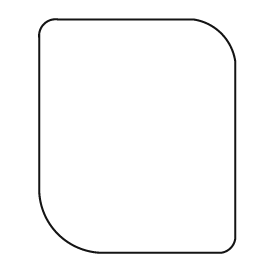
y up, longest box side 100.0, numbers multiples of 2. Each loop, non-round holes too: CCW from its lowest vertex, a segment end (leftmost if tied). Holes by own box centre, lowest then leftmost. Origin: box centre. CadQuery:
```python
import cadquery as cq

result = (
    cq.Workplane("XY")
    .moveTo(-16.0, -50.0)
    .lineTo(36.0, -50.0)
    .threePointArc((40.0, -48.0), (42.0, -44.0))
    .lineTo(42.0, 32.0)
    .threePointArc((36.0, 44.0), (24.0, 50.0))
    .lineTo(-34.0, 50.0)
    .threePointArc((-40.0, 48.0), (-42.0, 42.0))
    .lineTo(-42.0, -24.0)
    .threePointArc((-34.0, -42.0), (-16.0, -50.0))
    .close()
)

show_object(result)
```